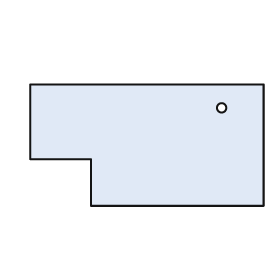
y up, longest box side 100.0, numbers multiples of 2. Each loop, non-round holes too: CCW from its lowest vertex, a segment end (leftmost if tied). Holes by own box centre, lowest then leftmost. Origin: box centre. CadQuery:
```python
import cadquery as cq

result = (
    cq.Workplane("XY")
    .moveTo(-24.0, -26.0)
    .lineTo(50.0, -26.0)
    .lineTo(50.0, 26.0)
    .lineTo(-50.0, 26.0)
    .lineTo(-50.0, -6.0)
    .lineTo(-24.0, -6.0)
    .close()
    .moveTo(32.0, 16.0)
    .circle(2.0)
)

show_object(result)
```